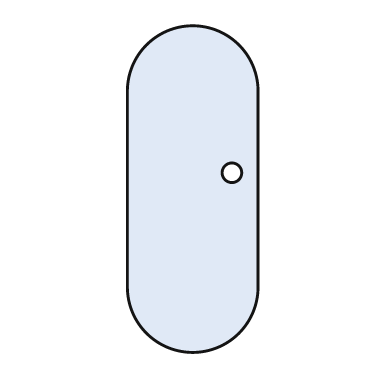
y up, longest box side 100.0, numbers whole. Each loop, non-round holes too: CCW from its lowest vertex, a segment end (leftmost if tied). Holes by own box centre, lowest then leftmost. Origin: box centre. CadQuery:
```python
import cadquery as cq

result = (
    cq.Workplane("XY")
    .moveTo(-20.0, -30.0)
    .threePointArc((0.0, -50.0), (20.0, -30.0))
    .lineTo(20.0, 30.0)
    .threePointArc((0.0, 50.0), (-20.0, 30.0))
    .close()
    .moveTo(12.0, 5.0)
    .circle(3.0)
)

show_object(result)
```